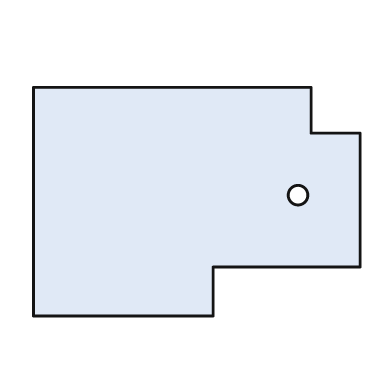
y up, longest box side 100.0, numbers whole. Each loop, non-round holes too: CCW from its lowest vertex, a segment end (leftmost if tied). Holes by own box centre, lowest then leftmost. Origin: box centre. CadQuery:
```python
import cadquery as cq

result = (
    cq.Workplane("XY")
    .moveTo(-50.0, -35.0)
    .lineTo(5.0, -35.0)
    .lineTo(5.0, -20.0)
    .lineTo(50.0, -20.0)
    .lineTo(50.0, 21.0)
    .lineTo(35.0, 21.0)
    .lineTo(35.0, 35.0)
    .lineTo(-50.0, 35.0)
    .close()
    .moveTo(31.0, 2.0)
    .circle(3.0)
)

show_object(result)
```